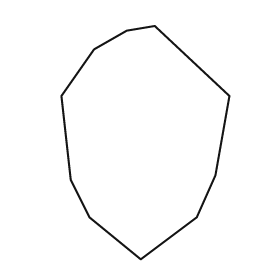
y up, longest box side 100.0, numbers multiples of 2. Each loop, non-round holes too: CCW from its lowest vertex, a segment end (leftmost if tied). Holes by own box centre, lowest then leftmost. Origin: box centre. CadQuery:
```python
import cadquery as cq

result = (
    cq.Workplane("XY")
    .moveTo(-2.0, -50.0)
    .lineTo(22.0, -32.0)
    .lineTo(30.0, -14.0)
    .lineTo(36.0, 20.0)
    .lineTo(4.0, 50.0)
    .lineTo(-8.0, 48.0)
    .lineTo(-22.0, 40.0)
    .lineTo(-36.0, 20.0)
    .lineTo(-32.0, -16.0)
    .lineTo(-24.0, -32.0)
    .close()
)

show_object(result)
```